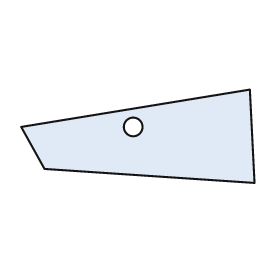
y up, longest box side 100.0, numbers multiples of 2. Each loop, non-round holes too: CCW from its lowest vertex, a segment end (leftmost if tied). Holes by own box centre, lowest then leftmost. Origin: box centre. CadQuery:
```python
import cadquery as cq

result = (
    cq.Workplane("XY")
    .moveTo(50.0, -20.0)
    .lineTo(48.0, 20.0)
    .lineTo(-50.0, 4.0)
    .lineTo(-40.0, -14.0)
    .close()
    .moveTo(-2.0, 4.0)
    .circle(4.0)
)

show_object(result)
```